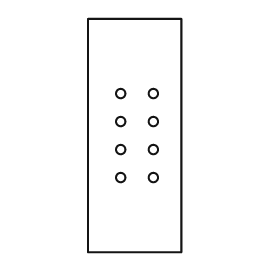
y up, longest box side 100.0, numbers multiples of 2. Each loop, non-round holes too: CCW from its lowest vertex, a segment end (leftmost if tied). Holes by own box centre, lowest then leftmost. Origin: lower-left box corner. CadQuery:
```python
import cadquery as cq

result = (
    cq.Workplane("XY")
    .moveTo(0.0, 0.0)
    .lineTo(40.0, 0.0)
    .lineTo(40.0, 100.0)
    .lineTo(0.0, 100.0)
    .close()
    .moveTo(14.0, 32.0)
    .circle(2.0)
    .moveTo(28.0, 32.0)
    .circle(2.0)
    .moveTo(14.0, 44.0)
    .circle(2.0)
    .moveTo(28.0, 44.0)
    .circle(2.0)
    .moveTo(14.0, 56.0)
    .circle(2.0)
    .moveTo(28.0, 56.0)
    .circle(2.0)
    .moveTo(14.0, 68.0)
    .circle(2.0)
    .moveTo(28.0, 68.0)
    .circle(2.0)
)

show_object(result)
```